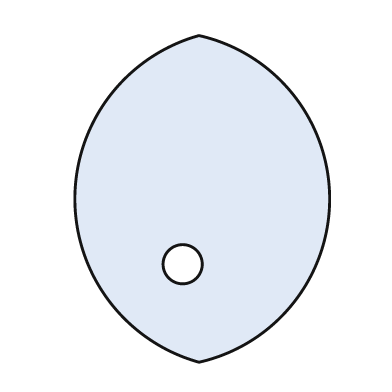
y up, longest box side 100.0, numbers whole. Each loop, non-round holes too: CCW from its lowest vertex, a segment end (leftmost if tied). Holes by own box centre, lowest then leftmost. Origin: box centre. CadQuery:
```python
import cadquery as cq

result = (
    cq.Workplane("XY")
    .moveTo(-1.0, -50.0)
    .threePointArc((39.0, 0.0), (-1.0, 50.0))
    .threePointArc((-39.0, 0.0), (-1.0, -50.0))
    .close()
    .moveTo(-6.0, -20.0)
    .circle(6.0)
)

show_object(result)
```